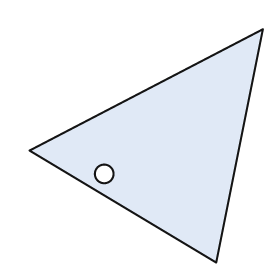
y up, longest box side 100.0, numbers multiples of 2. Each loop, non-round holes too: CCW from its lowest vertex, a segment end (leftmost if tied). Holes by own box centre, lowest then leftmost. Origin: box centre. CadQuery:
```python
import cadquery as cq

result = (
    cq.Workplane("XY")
    .moveTo(30.0, -50.0)
    .lineTo(50.0, 50.0)
    .lineTo(-50.0, -2.0)
    .close()
    .moveTo(-18.0, -12.0)
    .circle(4.0)
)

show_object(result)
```